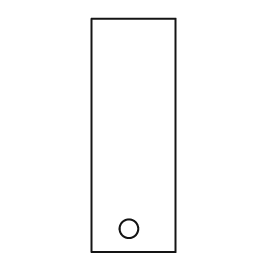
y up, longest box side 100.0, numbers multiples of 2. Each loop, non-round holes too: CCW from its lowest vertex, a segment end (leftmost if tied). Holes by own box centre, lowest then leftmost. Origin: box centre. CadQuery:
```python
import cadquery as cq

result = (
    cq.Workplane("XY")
    .moveTo(-18.0, -50.0)
    .lineTo(18.0, -50.0)
    .lineTo(18.0, 50.0)
    .lineTo(-18.0, 50.0)
    .close()
    .moveTo(-2.0, -40.0)
    .circle(4.0)
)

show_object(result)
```